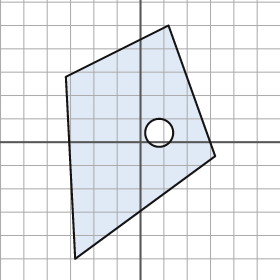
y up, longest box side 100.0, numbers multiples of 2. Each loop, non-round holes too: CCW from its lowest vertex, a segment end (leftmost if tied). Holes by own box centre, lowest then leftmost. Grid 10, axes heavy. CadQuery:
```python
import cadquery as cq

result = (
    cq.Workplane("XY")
    .moveTo(-28.0, -50.0)
    .lineTo(32.0, -6.0)
    .lineTo(12.0, 50.0)
    .lineTo(-32.0, 28.0)
    .close()
    .moveTo(8.0, 4.0)
    .circle(6.0)
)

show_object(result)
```